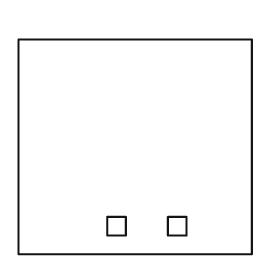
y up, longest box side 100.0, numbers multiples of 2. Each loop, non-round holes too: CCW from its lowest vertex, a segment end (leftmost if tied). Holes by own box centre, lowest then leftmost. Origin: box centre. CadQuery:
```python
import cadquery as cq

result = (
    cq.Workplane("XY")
    .moveTo(-50.0, -46.0)
    .lineTo(50.0, -46.0)
    .lineTo(50.0, 46.0)
    .lineTo(-50.0, 46.0)
    .close()
    .moveTo(-12.0, -38.0)
    .lineTo(-4.0, -38.0)
    .lineTo(-4.0, -30.0)
    .lineTo(-12.0, -30.0)
    .close()
    .moveTo(14.0, -38.0)
    .lineTo(22.0, -38.0)
    .lineTo(22.0, -30.0)
    .lineTo(14.0, -30.0)
    .close()
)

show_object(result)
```